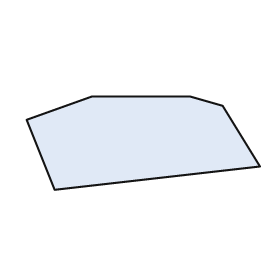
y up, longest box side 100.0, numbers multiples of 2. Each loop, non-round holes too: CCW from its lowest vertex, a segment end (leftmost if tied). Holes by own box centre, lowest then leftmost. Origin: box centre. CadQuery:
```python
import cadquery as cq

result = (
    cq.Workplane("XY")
    .moveTo(-38.0, -20.0)
    .lineTo(50.0, -10.0)
    .lineTo(34.0, 16.0)
    .lineTo(20.0, 20.0)
    .lineTo(-22.0, 20.0)
    .lineTo(-50.0, 10.0)
    .close()
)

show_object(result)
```